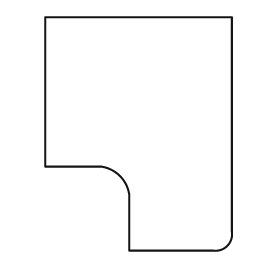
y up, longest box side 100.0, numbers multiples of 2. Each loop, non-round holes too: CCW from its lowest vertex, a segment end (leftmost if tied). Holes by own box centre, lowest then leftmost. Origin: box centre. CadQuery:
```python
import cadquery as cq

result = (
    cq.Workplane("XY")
    .moveTo(-4.0, -50.0)
    .lineTo(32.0, -50.0)
    .threePointArc((38.0, -48.0), (40.0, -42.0))
    .lineTo(40.0, 50.0)
    .lineTo(-40.0, 50.0)
    .lineTo(-40.0, -14.0)
    .lineTo(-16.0, -14.0)
    .threePointArc((-8.0, -18.0), (-4.0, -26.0))
    .close()
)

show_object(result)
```